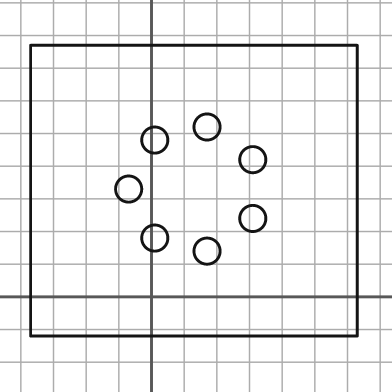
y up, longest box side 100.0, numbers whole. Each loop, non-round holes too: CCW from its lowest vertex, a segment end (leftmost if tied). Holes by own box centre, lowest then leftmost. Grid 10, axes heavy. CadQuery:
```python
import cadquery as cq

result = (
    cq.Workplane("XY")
    .moveTo(-37.0, -12.0)
    .lineTo(63.0, -12.0)
    .lineTo(63.0, 77.0)
    .lineTo(-37.0, 77.0)
    .close()
    .moveTo(17.0, 14.0)
    .circle(4.0)
    .moveTo(1.0, 18.0)
    .circle(4.0)
    .moveTo(31.0, 24.0)
    .circle(4.0)
    .moveTo(-7.0, 33.0)
    .circle(4.0)
    .moveTo(31.0, 42.0)
    .circle(4.0)
    .moveTo(1.0, 48.0)
    .circle(4.0)
    .moveTo(17.0, 52.0)
    .circle(4.0)
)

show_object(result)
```